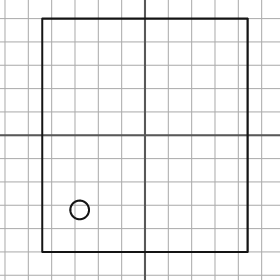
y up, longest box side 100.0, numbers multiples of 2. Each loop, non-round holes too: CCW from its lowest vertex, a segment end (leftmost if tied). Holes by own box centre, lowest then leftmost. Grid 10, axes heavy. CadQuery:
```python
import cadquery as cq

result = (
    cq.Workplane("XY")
    .moveTo(-44.0, -50.0)
    .lineTo(44.0, -50.0)
    .lineTo(44.0, 50.0)
    .lineTo(-44.0, 50.0)
    .close()
    .moveTo(-28.0, -32.0)
    .circle(4.0)
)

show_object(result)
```